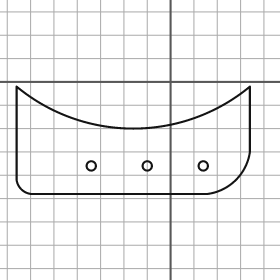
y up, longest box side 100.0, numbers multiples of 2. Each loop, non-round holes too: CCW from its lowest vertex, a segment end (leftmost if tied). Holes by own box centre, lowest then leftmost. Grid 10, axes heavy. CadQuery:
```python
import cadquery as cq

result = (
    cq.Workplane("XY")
    .moveTo(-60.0, -48.0)
    .lineTo(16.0, -48.0)
    .threePointArc((28.0, -42.0), (34.0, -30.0))
    .lineTo(34.0, -2.0)
    .threePointArc((-16.0, -20.0), (-66.0, -2.0))
    .lineTo(-66.0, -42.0)
    .threePointArc((-64.0, -46.0), (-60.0, -48.0))
    .close()
    .moveTo(-34.0, -36.0)
    .circle(2.0)
    .moveTo(-10.0, -36.0)
    .circle(2.0)
    .moveTo(14.0, -36.0)
    .circle(2.0)
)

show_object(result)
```